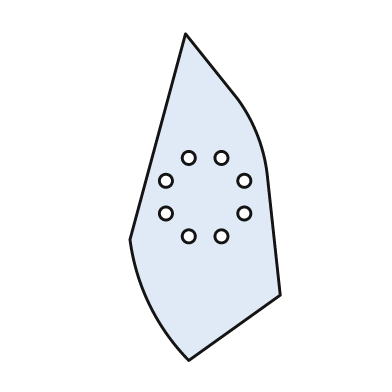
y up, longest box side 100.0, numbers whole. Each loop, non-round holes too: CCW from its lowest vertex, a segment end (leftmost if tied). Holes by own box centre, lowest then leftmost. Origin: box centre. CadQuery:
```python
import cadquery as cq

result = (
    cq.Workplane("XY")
    .moveTo(-5.0, -50.0)
    .lineTo(23.0, -30.0)
    .lineTo(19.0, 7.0)
    .threePointArc((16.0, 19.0), (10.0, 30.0))
    .lineTo(-6.0, 50.0)
    .lineTo(-23.0, -13.0)
    .threePointArc((-17.0, -33.0), (-5.0, -50.0))
    .close()
    .moveTo(-5.0, -12.0)
    .circle(2.0)
    .moveTo(5.0, -12.0)
    .circle(2.0)
    .moveTo(-12.0, -5.0)
    .circle(2.0)
    .moveTo(12.0, -5.0)
    .circle(2.0)
    .moveTo(-12.0, 5.0)
    .circle(2.0)
    .moveTo(12.0, 5.0)
    .circle(2.0)
    .moveTo(-5.0, 12.0)
    .circle(2.0)
    .moveTo(5.0, 12.0)
    .circle(2.0)
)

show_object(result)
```